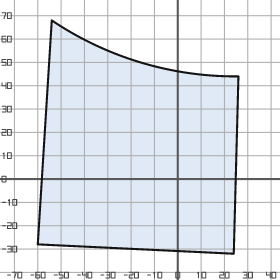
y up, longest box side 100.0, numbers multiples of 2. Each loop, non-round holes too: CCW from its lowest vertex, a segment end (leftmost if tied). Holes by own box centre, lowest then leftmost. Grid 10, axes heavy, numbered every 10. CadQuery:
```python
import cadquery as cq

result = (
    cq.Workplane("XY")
    .moveTo(24.0, -32.0)
    .lineTo(26.0, 44.0)
    .threePointArc((-16.0, 50.0), (-54.0, 68.0))
    .lineTo(-60.0, -28.0)
    .close()
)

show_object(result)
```